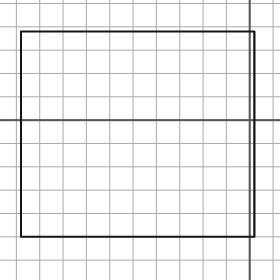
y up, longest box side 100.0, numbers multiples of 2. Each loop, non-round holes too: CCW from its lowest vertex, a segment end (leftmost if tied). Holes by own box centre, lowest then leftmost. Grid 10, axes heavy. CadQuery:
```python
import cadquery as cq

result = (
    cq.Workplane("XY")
    .moveTo(-98.0, -50.0)
    .lineTo(2.0, -50.0)
    .lineTo(2.0, 38.0)
    .lineTo(-98.0, 38.0)
    .close()
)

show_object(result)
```